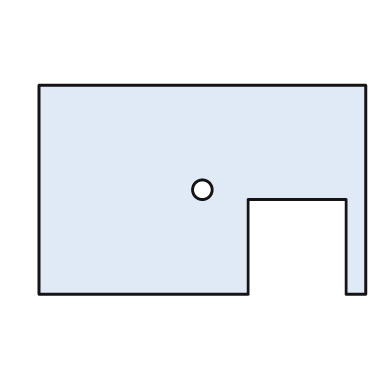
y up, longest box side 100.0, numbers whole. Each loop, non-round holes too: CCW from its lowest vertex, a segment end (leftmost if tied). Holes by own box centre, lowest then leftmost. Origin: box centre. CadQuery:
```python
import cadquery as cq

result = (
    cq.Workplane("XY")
    .moveTo(-50.0, -32.0)
    .lineTo(14.0, -32.0)
    .lineTo(14.0, -3.0)
    .lineTo(44.0, -3.0)
    .lineTo(44.0, -32.0)
    .lineTo(50.0, -32.0)
    .lineTo(50.0, 32.0)
    .lineTo(-50.0, 32.0)
    .close()
    .moveTo(0.0, 0.0)
    .circle(3.0)
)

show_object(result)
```